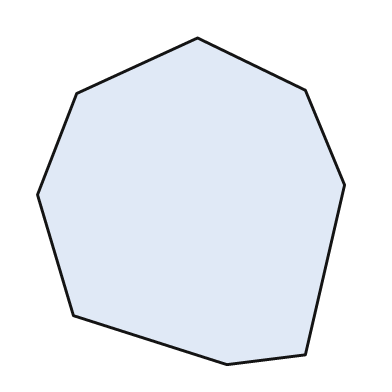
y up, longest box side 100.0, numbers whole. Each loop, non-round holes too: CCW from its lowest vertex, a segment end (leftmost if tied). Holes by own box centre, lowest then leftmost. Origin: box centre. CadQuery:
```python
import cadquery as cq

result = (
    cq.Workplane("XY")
    .moveTo(11.0, -50.0)
    .lineTo(35.0, -47.0)
    .lineTo(47.0, 5.0)
    .lineTo(35.0, 34.0)
    .lineTo(2.0, 50.0)
    .lineTo(-35.0, 33.0)
    .lineTo(-47.0, 2.0)
    .lineTo(-36.0, -35.0)
    .close()
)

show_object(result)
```